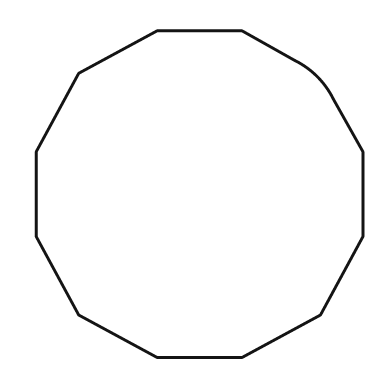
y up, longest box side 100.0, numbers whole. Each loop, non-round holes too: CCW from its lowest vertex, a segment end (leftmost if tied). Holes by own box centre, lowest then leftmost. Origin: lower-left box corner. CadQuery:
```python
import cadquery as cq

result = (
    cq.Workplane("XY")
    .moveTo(37.0, 0.0)
    .lineTo(63.0, 0.0)
    .lineTo(87.0, 13.0)
    .lineTo(100.0, 37.0)
    .lineTo(100.0, 63.0)
    .lineTo(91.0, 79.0)
    .threePointArc((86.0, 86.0), (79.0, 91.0))
    .lineTo(63.0, 100.0)
    .lineTo(37.0, 100.0)
    .lineTo(13.0, 87.0)
    .lineTo(0.0, 63.0)
    .lineTo(0.0, 37.0)
    .lineTo(13.0, 13.0)
    .close()
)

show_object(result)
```